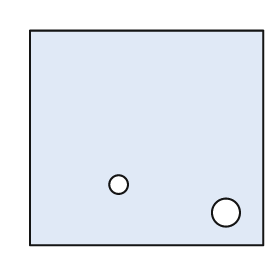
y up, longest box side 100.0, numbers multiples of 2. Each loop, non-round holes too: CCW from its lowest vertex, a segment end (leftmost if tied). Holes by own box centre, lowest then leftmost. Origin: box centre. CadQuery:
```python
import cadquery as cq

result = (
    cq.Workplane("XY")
    .moveTo(-50.0, -46.0)
    .lineTo(50.0, -46.0)
    .lineTo(50.0, 46.0)
    .lineTo(-50.0, 46.0)
    .close()
    .moveTo(34.0, -32.0)
    .circle(6.0)
    .moveTo(-12.0, -20.0)
    .circle(4.0)
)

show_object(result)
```